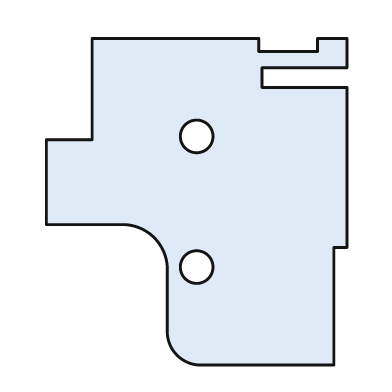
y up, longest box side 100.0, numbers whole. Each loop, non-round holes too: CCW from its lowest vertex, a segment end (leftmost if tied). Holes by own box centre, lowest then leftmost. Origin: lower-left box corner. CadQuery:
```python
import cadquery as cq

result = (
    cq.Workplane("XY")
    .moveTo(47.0, 0.0)
    .lineTo(88.0, 0.0)
    .lineTo(88.0, 36.0)
    .lineTo(92.0, 36.0)
    .lineTo(92.0, 85.0)
    .lineTo(66.0, 85.0)
    .lineTo(66.0, 91.0)
    .lineTo(92.0, 91.0)
    .lineTo(92.0, 100.0)
    .lineTo(83.0, 100.0)
    .lineTo(83.0, 96.0)
    .lineTo(65.0, 96.0)
    .lineTo(65.0, 100.0)
    .lineTo(14.0, 100.0)
    .lineTo(14.0, 69.0)
    .lineTo(0.0, 69.0)
    .lineTo(0.0, 43.0)
    .lineTo(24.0, 43.0)
    .threePointArc((33.0, 39.0), (37.0, 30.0))
    .lineTo(37.0, 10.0)
    .threePointArc((40.0, 3.0), (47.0, 0.0))
    .close()
    .moveTo(46.0, 30.0)
    .circle(5.0)
    .moveTo(46.0, 70.0)
    .circle(5.0)
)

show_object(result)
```